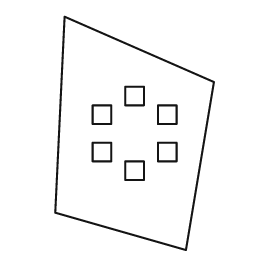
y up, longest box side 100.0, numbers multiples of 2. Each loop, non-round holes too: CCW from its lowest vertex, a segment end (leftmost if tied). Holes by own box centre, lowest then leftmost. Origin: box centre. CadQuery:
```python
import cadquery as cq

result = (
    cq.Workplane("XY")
    .moveTo(22.0, -50.0)
    .lineTo(34.0, 22.0)
    .lineTo(-30.0, 50.0)
    .lineTo(-34.0, -34.0)
    .close()
    .moveTo(-4.0, -20.0)
    .lineTo(4.0, -20.0)
    .lineTo(4.0, -12.0)
    .lineTo(-4.0, -12.0)
    .close()
    .moveTo(-18.0, -12.0)
    .lineTo(-10.0, -12.0)
    .lineTo(-10.0, -4.0)
    .lineTo(-18.0, -4.0)
    .close()
    .moveTo(10.0, -12.0)
    .lineTo(18.0, -12.0)
    .lineTo(18.0, -4.0)
    .lineTo(10.0, -4.0)
    .close()
    .moveTo(-18.0, 4.0)
    .lineTo(-10.0, 4.0)
    .lineTo(-10.0, 12.0)
    .lineTo(-18.0, 12.0)
    .close()
    .moveTo(10.0, 4.0)
    .lineTo(18.0, 4.0)
    .lineTo(18.0, 12.0)
    .lineTo(10.0, 12.0)
    .close()
    .moveTo(-4.0, 12.0)
    .lineTo(4.0, 12.0)
    .lineTo(4.0, 20.0)
    .lineTo(-4.0, 20.0)
    .close()
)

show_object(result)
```